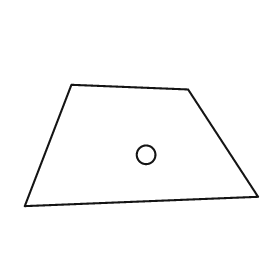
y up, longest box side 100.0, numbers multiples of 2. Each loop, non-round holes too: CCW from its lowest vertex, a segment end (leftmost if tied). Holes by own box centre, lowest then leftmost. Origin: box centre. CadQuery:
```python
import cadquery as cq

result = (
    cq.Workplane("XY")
    .moveTo(-50.0, -26.0)
    .lineTo(50.0, -22.0)
    .lineTo(20.0, 24.0)
    .lineTo(-30.0, 26.0)
    .close()
    .moveTo(2.0, -4.0)
    .circle(4.0)
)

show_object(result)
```